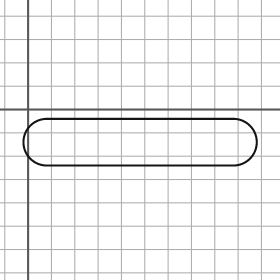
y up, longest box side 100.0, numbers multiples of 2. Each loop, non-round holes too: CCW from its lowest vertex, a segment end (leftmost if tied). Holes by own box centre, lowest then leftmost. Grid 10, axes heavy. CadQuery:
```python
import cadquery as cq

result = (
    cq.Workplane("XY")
    .moveTo(8.0, -24.0)
    .lineTo(88.0, -24.0)
    .threePointArc((98.0, -14.0), (88.0, -4.0))
    .lineTo(8.0, -4.0)
    .threePointArc((-2.0, -14.0), (8.0, -24.0))
    .close()
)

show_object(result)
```